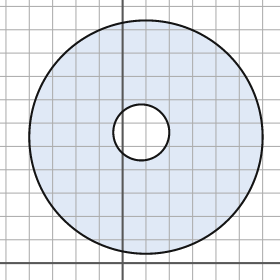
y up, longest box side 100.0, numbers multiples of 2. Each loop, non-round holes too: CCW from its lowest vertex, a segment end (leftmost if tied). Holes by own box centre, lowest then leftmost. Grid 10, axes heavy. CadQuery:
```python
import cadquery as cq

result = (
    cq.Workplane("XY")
    .moveTo(10.0, 54.0)
    .circle(50.0)
    .moveTo(8.0, 56.0)
    .circle(12.0)
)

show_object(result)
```